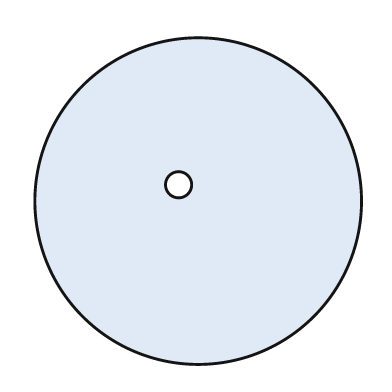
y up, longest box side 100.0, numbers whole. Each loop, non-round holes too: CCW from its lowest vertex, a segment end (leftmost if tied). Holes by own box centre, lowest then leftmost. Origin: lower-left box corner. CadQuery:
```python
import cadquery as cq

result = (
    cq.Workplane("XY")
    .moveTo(50.0, 50.0)
    .circle(50.0)
    .moveTo(44.0, 55.0)
    .circle(4.0)
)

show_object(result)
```